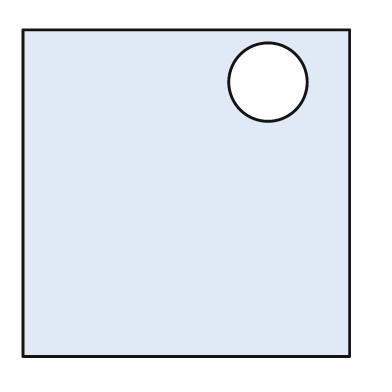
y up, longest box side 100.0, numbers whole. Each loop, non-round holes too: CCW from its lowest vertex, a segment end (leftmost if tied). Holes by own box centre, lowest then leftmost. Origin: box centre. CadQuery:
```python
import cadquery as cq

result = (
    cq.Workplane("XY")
    .moveTo(-50.0, -50.0)
    .lineTo(50.0, -50.0)
    .lineTo(50.0, 50.0)
    .lineTo(-50.0, 50.0)
    .close()
    .moveTo(25.0, 34.0)
    .circle(12.0)
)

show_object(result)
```